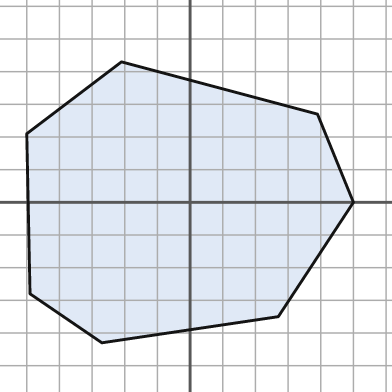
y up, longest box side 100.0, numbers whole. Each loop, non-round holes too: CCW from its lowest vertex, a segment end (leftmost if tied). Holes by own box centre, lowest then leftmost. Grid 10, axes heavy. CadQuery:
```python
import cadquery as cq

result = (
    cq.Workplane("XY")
    .moveTo(-27.0, -43.0)
    .lineTo(27.0, -35.0)
    .lineTo(50.0, 0.0)
    .lineTo(39.0, 27.0)
    .lineTo(-21.0, 43.0)
    .lineTo(-50.0, 21.0)
    .lineTo(-49.0, -28.0)
    .close()
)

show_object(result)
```